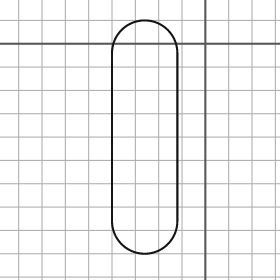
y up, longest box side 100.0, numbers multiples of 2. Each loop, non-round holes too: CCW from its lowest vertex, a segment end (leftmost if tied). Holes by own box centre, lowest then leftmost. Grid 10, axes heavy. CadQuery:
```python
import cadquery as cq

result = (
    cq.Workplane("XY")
    .moveTo(-40.0, -76.0)
    .threePointArc((-26.0, -90.0), (-12.0, -76.0))
    .lineTo(-12.0, -4.0)
    .threePointArc((-26.0, 10.0), (-40.0, -4.0))
    .close()
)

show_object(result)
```